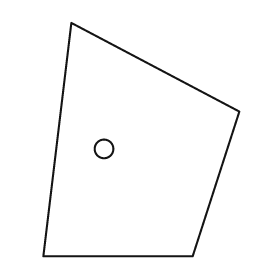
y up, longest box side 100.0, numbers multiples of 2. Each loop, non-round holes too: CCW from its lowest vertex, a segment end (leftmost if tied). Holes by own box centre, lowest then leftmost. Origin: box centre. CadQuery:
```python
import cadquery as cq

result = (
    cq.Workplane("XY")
    .moveTo(-42.0, -50.0)
    .lineTo(22.0, -50.0)
    .lineTo(42.0, 12.0)
    .lineTo(-30.0, 50.0)
    .close()
    .moveTo(-16.0, -4.0)
    .circle(4.0)
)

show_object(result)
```